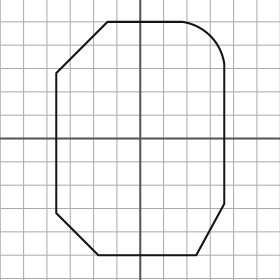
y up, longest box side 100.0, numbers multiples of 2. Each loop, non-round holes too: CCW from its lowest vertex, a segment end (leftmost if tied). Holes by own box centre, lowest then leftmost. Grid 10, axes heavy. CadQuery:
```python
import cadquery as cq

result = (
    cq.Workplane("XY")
    .moveTo(-18.0, -50.0)
    .lineTo(24.0, -50.0)
    .lineTo(36.0, -28.0)
    .lineTo(36.0, 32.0)
    .threePointArc((30.0, 44.0), (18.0, 50.0))
    .lineTo(-14.0, 50.0)
    .lineTo(-36.0, 28.0)
    .lineTo(-36.0, -32.0)
    .close()
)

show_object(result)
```